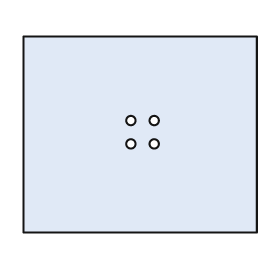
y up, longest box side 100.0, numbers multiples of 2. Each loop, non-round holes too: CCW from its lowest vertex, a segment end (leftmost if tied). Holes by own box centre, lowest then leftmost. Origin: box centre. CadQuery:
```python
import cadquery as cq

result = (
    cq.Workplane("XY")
    .moveTo(-50.0, -42.0)
    .lineTo(50.0, -42.0)
    .lineTo(50.0, 42.0)
    .lineTo(-50.0, 42.0)
    .close()
    .moveTo(-4.0, -4.0)
    .circle(2.0)
    .moveTo(6.0, -4.0)
    .circle(2.0)
    .moveTo(-4.0, 6.0)
    .circle(2.0)
    .moveTo(6.0, 6.0)
    .circle(2.0)
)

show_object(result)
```